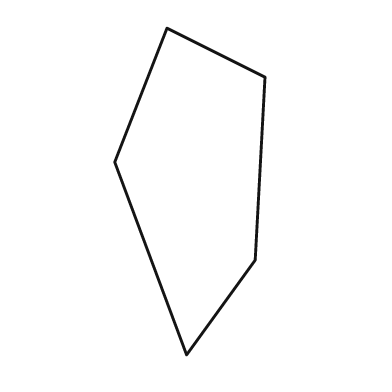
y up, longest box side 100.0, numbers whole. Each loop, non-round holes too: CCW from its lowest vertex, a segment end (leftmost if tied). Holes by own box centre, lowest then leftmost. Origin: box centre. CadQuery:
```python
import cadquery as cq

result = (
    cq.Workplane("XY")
    .moveTo(-1.0, -50.0)
    .lineTo(20.0, -21.0)
    .lineTo(23.0, 35.0)
    .lineTo(-7.0, 50.0)
    .lineTo(-23.0, 9.0)
    .close()
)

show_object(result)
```